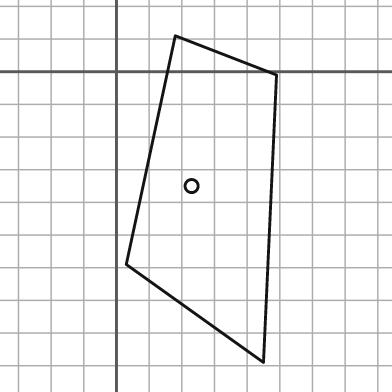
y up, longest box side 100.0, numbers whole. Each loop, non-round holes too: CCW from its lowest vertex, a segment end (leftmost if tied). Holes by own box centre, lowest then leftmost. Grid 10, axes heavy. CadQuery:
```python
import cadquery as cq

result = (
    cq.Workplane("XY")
    .moveTo(45.0, -89.0)
    .lineTo(49.0, -1.0)
    .lineTo(18.0, 11.0)
    .lineTo(3.0, -59.0)
    .close()
    .moveTo(23.0, -35.0)
    .circle(2.0)
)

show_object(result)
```